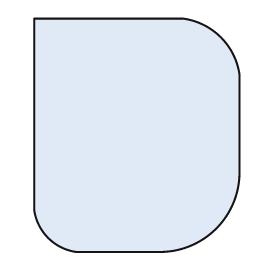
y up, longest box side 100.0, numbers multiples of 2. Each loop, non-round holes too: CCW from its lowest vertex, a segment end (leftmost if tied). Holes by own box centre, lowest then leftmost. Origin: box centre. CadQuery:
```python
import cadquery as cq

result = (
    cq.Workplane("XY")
    .moveTo(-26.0, -50.0)
    .lineTo(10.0, -50.0)
    .threePointArc((34.0, -40.0), (44.0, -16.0))
    .lineTo(44.0, 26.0)
    .threePointArc((36.0, 42.0), (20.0, 50.0))
    .lineTo(-44.0, 50.0)
    .lineTo(-44.0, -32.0)
    .threePointArc((-38.0, -44.0), (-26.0, -50.0))
    .close()
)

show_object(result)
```